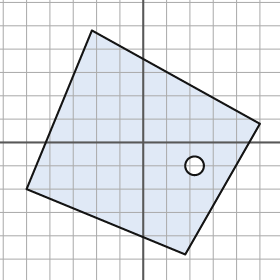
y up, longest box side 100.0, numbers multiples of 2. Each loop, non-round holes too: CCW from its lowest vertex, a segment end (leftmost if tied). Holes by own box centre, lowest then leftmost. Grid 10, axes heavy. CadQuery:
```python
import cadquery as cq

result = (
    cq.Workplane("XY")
    .moveTo(18.0, -48.0)
    .lineTo(50.0, 8.0)
    .lineTo(-22.0, 48.0)
    .lineTo(-50.0, -20.0)
    .close()
    .moveTo(22.0, -10.0)
    .circle(4.0)
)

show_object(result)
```